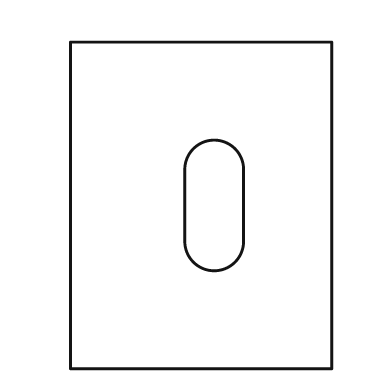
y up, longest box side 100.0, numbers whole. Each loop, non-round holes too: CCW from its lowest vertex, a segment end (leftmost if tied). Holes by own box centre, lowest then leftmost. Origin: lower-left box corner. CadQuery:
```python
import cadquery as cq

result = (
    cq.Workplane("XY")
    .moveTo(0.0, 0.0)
    .lineTo(80.0, 0.0)
    .lineTo(80.0, 100.0)
    .lineTo(0.0, 100.0)
    .close()
    .moveTo(35.0, 39.0)
    .threePointArc((44.0, 30.0), (53.0, 39.0))
    .lineTo(53.0, 61.0)
    .threePointArc((44.0, 70.0), (35.0, 61.0))
    .close()
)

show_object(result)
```